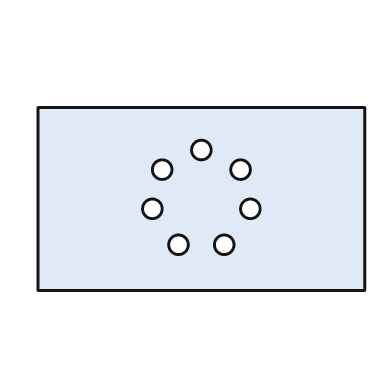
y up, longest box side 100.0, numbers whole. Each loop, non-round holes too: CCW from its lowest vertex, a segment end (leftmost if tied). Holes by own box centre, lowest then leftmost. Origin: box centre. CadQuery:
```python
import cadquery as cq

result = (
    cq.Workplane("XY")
    .moveTo(-50.0, -28.0)
    .lineTo(50.0, -28.0)
    .lineTo(50.0, 28.0)
    .lineTo(-50.0, 28.0)
    .close()
    .moveTo(-7.0, -14.0)
    .circle(3.0)
    .moveTo(7.0, -14.0)
    .circle(3.0)
    .moveTo(-15.0, -3.0)
    .circle(3.0)
    .moveTo(15.0, -3.0)
    .circle(3.0)
    .moveTo(-12.0, 9.0)
    .circle(3.0)
    .moveTo(12.0, 9.0)
    .circle(3.0)
    .moveTo(0.0, 15.0)
    .circle(3.0)
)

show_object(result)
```